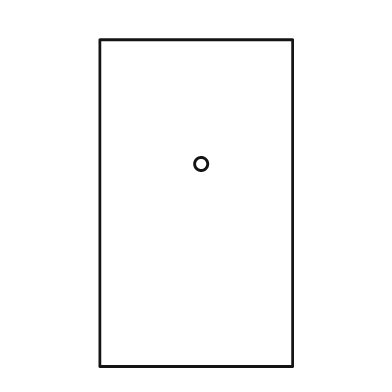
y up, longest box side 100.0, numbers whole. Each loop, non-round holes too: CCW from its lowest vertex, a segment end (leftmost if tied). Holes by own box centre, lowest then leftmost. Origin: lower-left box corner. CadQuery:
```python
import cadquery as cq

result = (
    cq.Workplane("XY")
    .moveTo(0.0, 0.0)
    .lineTo(59.0, 0.0)
    .lineTo(59.0, 100.0)
    .lineTo(0.0, 100.0)
    .close()
    .moveTo(31.0, 62.0)
    .circle(2.0)
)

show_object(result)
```